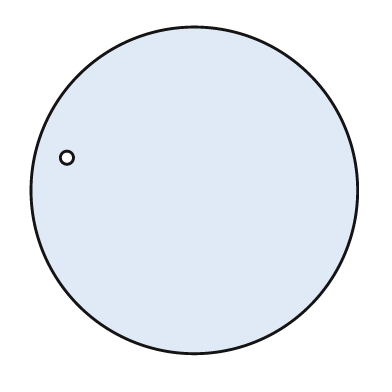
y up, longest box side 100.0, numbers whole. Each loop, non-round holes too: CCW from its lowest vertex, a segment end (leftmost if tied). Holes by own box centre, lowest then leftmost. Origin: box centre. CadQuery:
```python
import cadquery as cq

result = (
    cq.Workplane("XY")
    .moveTo(0.0, 0.0)
    .circle(50.0)
    .moveTo(-39.0, 10.0)
    .circle(2.0)
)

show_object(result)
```